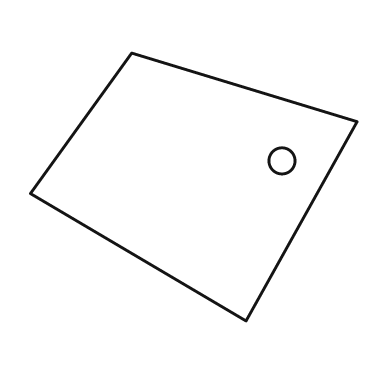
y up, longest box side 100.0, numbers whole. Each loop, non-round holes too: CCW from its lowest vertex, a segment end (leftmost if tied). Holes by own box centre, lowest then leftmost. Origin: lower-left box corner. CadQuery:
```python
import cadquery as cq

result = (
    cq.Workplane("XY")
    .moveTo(66.0, 0.0)
    .lineTo(100.0, 61.0)
    .lineTo(31.0, 82.0)
    .lineTo(0.0, 39.0)
    .close()
    .moveTo(77.0, 49.0)
    .circle(4.0)
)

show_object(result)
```